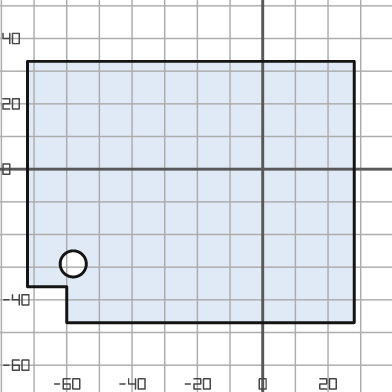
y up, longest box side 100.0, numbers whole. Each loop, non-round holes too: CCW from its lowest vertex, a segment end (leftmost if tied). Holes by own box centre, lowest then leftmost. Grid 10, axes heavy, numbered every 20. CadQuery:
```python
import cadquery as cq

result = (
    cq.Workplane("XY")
    .moveTo(-60.0, -47.0)
    .lineTo(28.0, -47.0)
    .lineTo(28.0, 33.0)
    .lineTo(-72.0, 33.0)
    .lineTo(-72.0, -36.0)
    .lineTo(-60.0, -36.0)
    .close()
    .moveTo(-58.0, -29.0)
    .circle(4.0)
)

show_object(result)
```